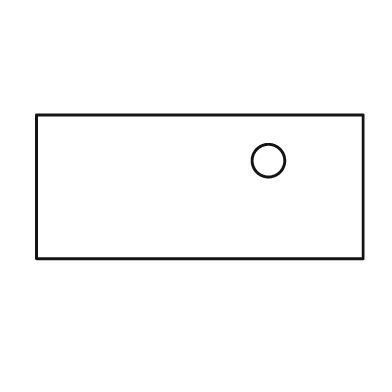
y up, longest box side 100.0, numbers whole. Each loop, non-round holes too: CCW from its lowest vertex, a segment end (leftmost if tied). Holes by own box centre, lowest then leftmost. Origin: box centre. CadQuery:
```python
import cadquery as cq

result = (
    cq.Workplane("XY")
    .moveTo(-50.0, -22.0)
    .lineTo(50.0, -22.0)
    .lineTo(50.0, 22.0)
    .lineTo(-50.0, 22.0)
    .close()
    .moveTo(21.0, 8.0)
    .circle(5.0)
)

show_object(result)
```